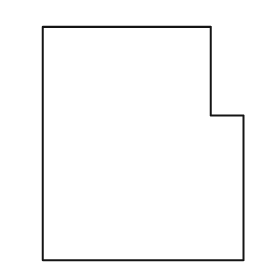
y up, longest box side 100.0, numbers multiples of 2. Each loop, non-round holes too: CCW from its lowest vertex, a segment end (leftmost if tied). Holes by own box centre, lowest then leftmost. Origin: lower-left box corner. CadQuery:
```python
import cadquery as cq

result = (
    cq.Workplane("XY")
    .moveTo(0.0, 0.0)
    .lineTo(86.0, 0.0)
    .lineTo(86.0, 62.0)
    .lineTo(72.0, 62.0)
    .lineTo(72.0, 100.0)
    .lineTo(0.0, 100.0)
    .close()
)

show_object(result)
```